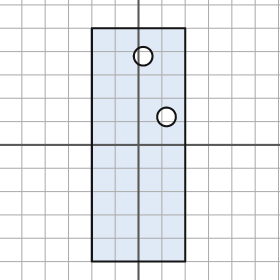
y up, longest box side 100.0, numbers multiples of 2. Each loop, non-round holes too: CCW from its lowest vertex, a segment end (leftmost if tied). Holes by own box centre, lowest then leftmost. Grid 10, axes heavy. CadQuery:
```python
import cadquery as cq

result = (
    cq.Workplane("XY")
    .moveTo(-20.0, -50.0)
    .lineTo(20.0, -50.0)
    .lineTo(20.0, 50.0)
    .lineTo(-20.0, 50.0)
    .close()
    .moveTo(12.0, 12.0)
    .circle(4.0)
    .moveTo(2.0, 38.0)
    .circle(4.0)
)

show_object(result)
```